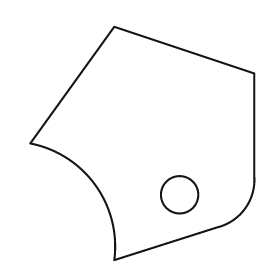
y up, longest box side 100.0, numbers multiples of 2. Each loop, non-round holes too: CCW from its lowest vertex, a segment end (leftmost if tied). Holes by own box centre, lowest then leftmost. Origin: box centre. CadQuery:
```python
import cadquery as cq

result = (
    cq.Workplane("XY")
    .moveTo(-12.0, -50.0)
    .lineTo(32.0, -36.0)
    .threePointArc((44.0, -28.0), (48.0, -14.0))
    .lineTo(48.0, 30.0)
    .lineTo(-12.0, 50.0)
    .lineTo(-48.0, 0.0)
    .threePointArc((-20.0, -18.0), (-12.0, -50.0))
    .close()
    .moveTo(16.0, -22.0)
    .circle(8.0)
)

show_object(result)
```